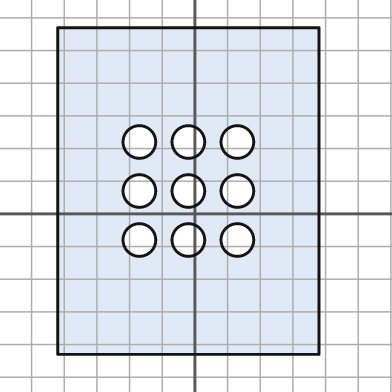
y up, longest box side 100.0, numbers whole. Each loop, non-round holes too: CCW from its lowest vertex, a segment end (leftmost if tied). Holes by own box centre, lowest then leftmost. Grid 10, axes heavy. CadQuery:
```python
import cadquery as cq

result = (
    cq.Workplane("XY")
    .moveTo(-42.0, -43.0)
    .lineTo(38.0, -43.0)
    .lineTo(38.0, 57.0)
    .lineTo(-42.0, 57.0)
    .close()
    .moveTo(-17.0, -8.0)
    .circle(5.0)
    .moveTo(-2.0, -8.0)
    .circle(5.0)
    .moveTo(13.0, -8.0)
    .circle(5.0)
    .moveTo(-17.0, 7.0)
    .circle(5.0)
    .moveTo(-2.0, 7.0)
    .circle(5.0)
    .moveTo(13.0, 7.0)
    .circle(5.0)
    .moveTo(-17.0, 22.0)
    .circle(5.0)
    .moveTo(-2.0, 22.0)
    .circle(5.0)
    .moveTo(13.0, 22.0)
    .circle(5.0)
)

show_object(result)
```